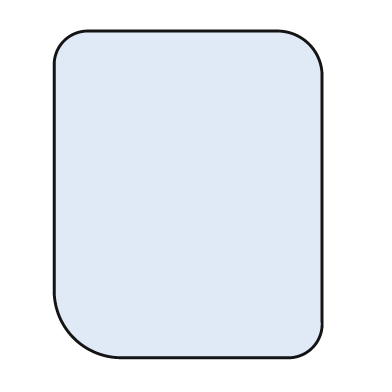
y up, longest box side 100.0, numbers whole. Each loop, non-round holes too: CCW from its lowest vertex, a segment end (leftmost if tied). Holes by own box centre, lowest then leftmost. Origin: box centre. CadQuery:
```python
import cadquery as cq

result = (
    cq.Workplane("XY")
    .moveTo(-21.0, -50.0)
    .lineTo(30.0, -50.0)
    .threePointArc((38.0, -47.0), (41.0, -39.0))
    .lineTo(41.0, 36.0)
    .threePointArc((37.0, 46.0), (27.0, 50.0))
    .lineTo(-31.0, 50.0)
    .threePointArc((-38.0, 47.0), (-41.0, 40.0))
    .lineTo(-41.0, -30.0)
    .threePointArc((-35.0, -44.0), (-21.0, -50.0))
    .close()
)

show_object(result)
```